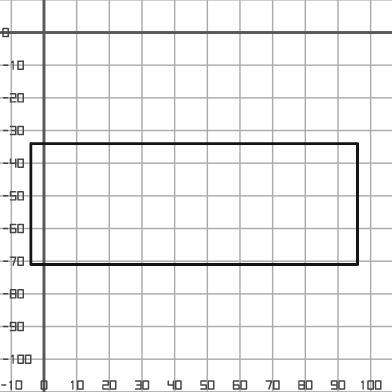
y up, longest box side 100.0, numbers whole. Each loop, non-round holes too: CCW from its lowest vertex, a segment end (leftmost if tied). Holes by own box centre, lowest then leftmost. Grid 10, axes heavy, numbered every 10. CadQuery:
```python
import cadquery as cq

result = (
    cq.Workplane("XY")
    .moveTo(-4.0, -71.0)
    .lineTo(96.0, -71.0)
    .lineTo(96.0, -34.0)
    .lineTo(-4.0, -34.0)
    .close()
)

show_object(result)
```